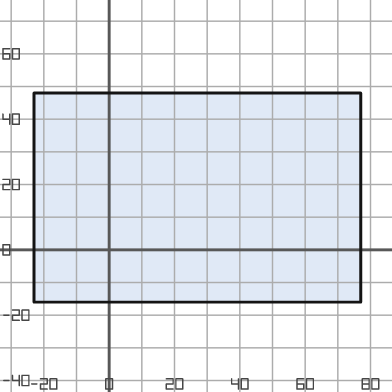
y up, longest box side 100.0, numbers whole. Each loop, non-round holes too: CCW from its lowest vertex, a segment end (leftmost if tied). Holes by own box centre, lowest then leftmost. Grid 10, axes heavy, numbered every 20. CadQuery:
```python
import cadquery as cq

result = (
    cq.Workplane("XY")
    .moveTo(-23.0, -16.0)
    .lineTo(77.0, -16.0)
    .lineTo(77.0, 48.0)
    .lineTo(-23.0, 48.0)
    .close()
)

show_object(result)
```